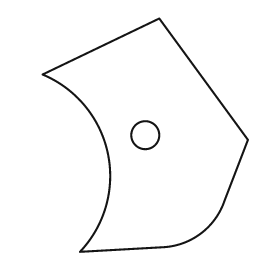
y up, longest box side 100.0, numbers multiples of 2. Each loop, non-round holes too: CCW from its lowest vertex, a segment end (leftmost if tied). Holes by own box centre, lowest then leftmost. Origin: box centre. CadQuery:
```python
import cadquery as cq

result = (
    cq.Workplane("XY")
    .moveTo(-28.0, -50.0)
    .lineTo(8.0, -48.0)
    .threePointArc((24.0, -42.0), (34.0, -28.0))
    .lineTo(44.0, -2.0)
    .lineTo(6.0, 50.0)
    .lineTo(-44.0, 26.0)
    .threePointArc((-16.0, -8.0), (-28.0, -50.0))
    .close()
    .moveTo(0.0, 0.0)
    .circle(6.0)
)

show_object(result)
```